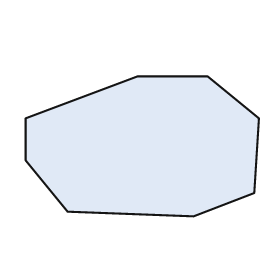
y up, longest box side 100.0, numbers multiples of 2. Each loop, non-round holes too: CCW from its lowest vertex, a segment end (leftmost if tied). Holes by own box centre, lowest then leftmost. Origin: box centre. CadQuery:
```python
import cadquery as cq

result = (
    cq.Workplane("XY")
    .moveTo(22.0, -30.0)
    .lineTo(48.0, -20.0)
    .lineTo(50.0, 12.0)
    .lineTo(28.0, 30.0)
    .lineTo(-2.0, 30.0)
    .lineTo(-50.0, 12.0)
    .lineTo(-50.0, -6.0)
    .lineTo(-32.0, -28.0)
    .close()
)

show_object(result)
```